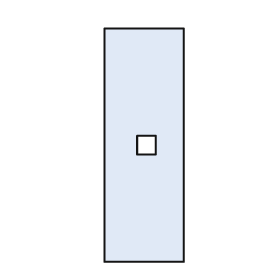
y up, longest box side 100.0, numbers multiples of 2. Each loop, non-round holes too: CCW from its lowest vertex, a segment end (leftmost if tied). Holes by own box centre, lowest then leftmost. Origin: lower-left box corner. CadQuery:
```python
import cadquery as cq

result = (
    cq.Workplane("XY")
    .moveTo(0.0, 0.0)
    .lineTo(34.0, 0.0)
    .lineTo(34.0, 100.0)
    .lineTo(0.0, 100.0)
    .close()
    .moveTo(14.0, 46.0)
    .lineTo(22.0, 46.0)
    .lineTo(22.0, 54.0)
    .lineTo(14.0, 54.0)
    .close()
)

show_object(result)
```